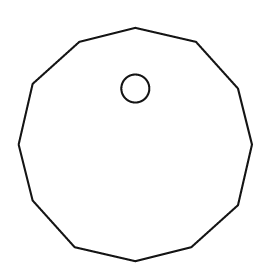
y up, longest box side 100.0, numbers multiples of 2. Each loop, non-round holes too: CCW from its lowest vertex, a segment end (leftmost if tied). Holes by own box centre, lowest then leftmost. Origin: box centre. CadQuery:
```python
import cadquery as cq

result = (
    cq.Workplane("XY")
    .moveTo(0.0, -50.0)
    .lineTo(24.0, -44.0)
    .lineTo(44.0, -26.0)
    .lineTo(50.0, 0.0)
    .lineTo(44.0, 24.0)
    .lineTo(26.0, 44.0)
    .lineTo(0.0, 50.0)
    .lineTo(-24.0, 44.0)
    .lineTo(-44.0, 26.0)
    .lineTo(-50.0, 0.0)
    .lineTo(-44.0, -24.0)
    .lineTo(-26.0, -44.0)
    .close()
    .moveTo(0.0, 24.0)
    .circle(6.0)
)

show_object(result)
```